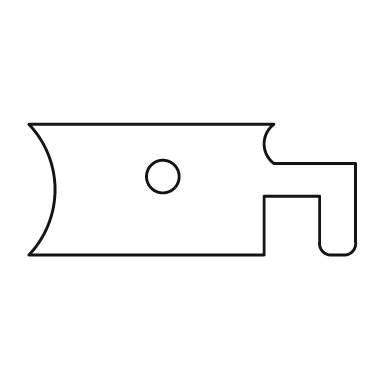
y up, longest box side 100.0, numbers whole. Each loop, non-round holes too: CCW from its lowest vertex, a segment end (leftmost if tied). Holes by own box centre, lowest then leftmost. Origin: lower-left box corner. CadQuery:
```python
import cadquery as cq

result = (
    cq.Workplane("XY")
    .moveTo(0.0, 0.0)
    .lineTo(72.0, 0.0)
    .lineTo(72.0, 18.0)
    .lineTo(89.0, 18.0)
    .lineTo(89.0, 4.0)
    .threePointArc((90.0, 1.0), (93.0, 0.0))
    .lineTo(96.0, 0.0)
    .threePointArc((99.0, 1.0), (100.0, 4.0))
    .lineTo(100.0, 28.0)
    .lineTo(75.0, 28.0)
    .threePointArc((72.0, 34.0), (75.0, 40.0))
    .lineTo(0.0, 40.0)
    .threePointArc((8.0, 20.0), (0.0, 0.0))
    .close()
    .moveTo(41.0, 24.0)
    .circle(5.0)
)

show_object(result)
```